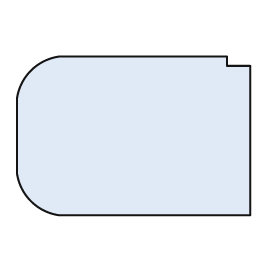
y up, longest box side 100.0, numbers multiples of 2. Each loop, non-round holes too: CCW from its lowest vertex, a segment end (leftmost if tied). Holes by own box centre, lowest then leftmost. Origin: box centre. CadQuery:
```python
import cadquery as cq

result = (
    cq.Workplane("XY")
    .moveTo(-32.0, -34.0)
    .lineTo(50.0, -34.0)
    .lineTo(50.0, 30.0)
    .lineTo(40.0, 30.0)
    .lineTo(40.0, 34.0)
    .lineTo(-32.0, 34.0)
    .threePointArc((-44.0, 28.0), (-50.0, 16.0))
    .lineTo(-50.0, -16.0)
    .threePointArc((-44.0, -28.0), (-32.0, -34.0))
    .close()
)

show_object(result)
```